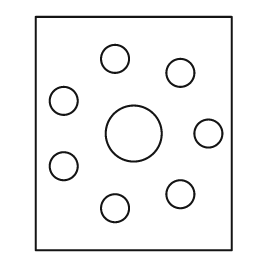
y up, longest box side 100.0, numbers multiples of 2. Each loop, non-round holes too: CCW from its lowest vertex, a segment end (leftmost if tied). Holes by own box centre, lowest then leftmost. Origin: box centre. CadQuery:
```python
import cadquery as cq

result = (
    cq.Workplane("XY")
    .moveTo(-42.0, -50.0)
    .lineTo(42.0, -50.0)
    .lineTo(42.0, 50.0)
    .lineTo(-42.0, 50.0)
    .close()
    .moveTo(-8.0, -32.0)
    .circle(6.0)
    .moveTo(20.0, -26.0)
    .circle(6.0)
    .moveTo(-30.0, -14.0)
    .circle(6.0)
    .moveTo(0.0, 0.0)
    .circle(12.0)
    .moveTo(32.0, 0.0)
    .circle(6.0)
    .moveTo(-30.0, 14.0)
    .circle(6.0)
    .moveTo(20.0, 26.0)
    .circle(6.0)
    .moveTo(-8.0, 32.0)
    .circle(6.0)
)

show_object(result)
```